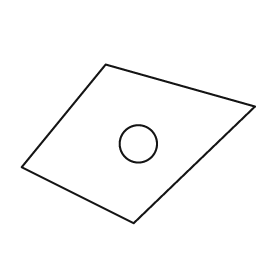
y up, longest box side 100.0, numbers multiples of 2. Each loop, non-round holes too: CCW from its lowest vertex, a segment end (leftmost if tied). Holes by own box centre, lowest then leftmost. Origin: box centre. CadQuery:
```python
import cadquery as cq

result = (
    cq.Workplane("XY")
    .moveTo(-2.0, -34.0)
    .lineTo(50.0, 16.0)
    .lineTo(-14.0, 34.0)
    .lineTo(-50.0, -10.0)
    .close()
    .moveTo(0.0, 0.0)
    .circle(8.0)
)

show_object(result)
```